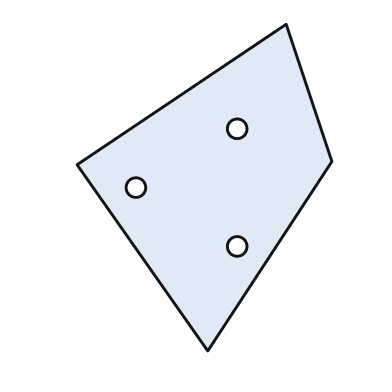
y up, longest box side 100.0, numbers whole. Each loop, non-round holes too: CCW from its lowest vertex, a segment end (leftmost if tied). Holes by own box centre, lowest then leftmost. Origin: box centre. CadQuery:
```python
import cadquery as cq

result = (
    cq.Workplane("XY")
    .moveTo(1.0, -50.0)
    .lineTo(39.0, 8.0)
    .lineTo(25.0, 50.0)
    .lineTo(-39.0, 7.0)
    .close()
    .moveTo(10.0, -18.0)
    .circle(3.0)
    .moveTo(-21.0, 0.0)
    .circle(3.0)
    .moveTo(10.0, 18.0)
    .circle(3.0)
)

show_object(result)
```